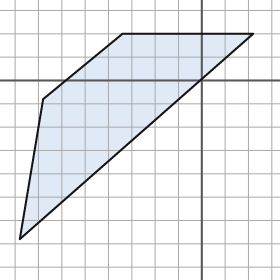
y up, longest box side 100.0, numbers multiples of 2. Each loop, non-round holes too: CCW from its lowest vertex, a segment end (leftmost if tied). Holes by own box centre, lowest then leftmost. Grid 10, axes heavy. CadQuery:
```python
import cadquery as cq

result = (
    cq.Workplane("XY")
    .moveTo(-78.0, -68.0)
    .lineTo(22.0, 20.0)
    .lineTo(-34.0, 20.0)
    .lineTo(-68.0, -8.0)
    .close()
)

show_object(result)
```